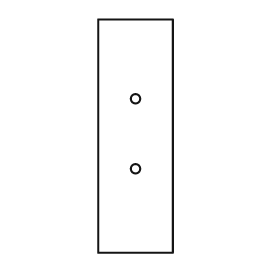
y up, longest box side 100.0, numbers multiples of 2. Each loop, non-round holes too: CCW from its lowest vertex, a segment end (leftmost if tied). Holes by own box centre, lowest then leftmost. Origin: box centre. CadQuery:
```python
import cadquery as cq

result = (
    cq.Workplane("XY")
    .moveTo(-16.0, -50.0)
    .lineTo(16.0, -50.0)
    .lineTo(16.0, 50.0)
    .lineTo(-16.0, 50.0)
    .close()
    .moveTo(0.0, -14.0)
    .circle(2.0)
    .moveTo(0.0, 16.0)
    .circle(2.0)
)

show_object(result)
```